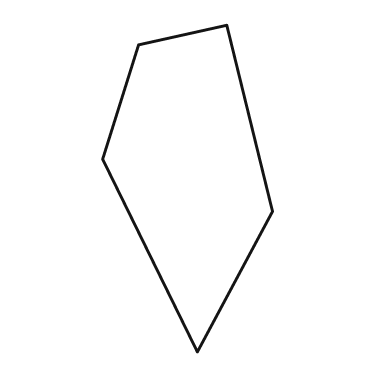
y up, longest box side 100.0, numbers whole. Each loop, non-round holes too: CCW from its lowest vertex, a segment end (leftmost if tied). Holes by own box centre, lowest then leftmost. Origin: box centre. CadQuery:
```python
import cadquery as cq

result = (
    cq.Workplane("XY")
    .moveTo(3.0, -50.0)
    .lineTo(26.0, -7.0)
    .lineTo(12.0, 50.0)
    .lineTo(-15.0, 44.0)
    .lineTo(-26.0, 9.0)
    .close()
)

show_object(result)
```